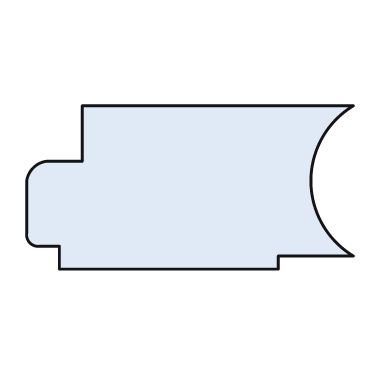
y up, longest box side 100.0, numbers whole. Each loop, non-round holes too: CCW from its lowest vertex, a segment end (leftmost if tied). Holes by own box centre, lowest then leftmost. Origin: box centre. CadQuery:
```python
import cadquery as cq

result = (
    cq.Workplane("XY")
    .moveTo(-40.0, -25.0)
    .lineTo(27.0, -25.0)
    .lineTo(27.0, -21.0)
    .lineTo(50.0, -21.0)
    .threePointArc((37.0, 2.0), (50.0, 25.0))
    .lineTo(-33.0, 25.0)
    .lineTo(-33.0, 8.0)
    .lineTo(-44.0, 8.0)
    .threePointArc((-48.0, 6.0), (-50.0, 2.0))
    .lineTo(-50.0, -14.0)
    .threePointArc((-49.0, -17.0), (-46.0, -18.0))
    .lineTo(-40.0, -18.0)
    .close()
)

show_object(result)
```